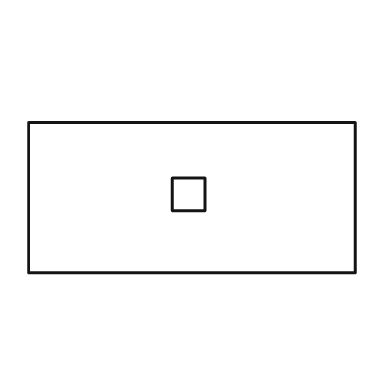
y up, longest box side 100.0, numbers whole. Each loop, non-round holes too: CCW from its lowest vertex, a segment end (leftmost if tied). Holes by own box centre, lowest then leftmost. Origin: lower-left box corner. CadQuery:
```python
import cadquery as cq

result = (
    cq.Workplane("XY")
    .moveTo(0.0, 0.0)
    .lineTo(100.0, 0.0)
    .lineTo(100.0, 46.0)
    .lineTo(0.0, 46.0)
    .close()
    .moveTo(44.0, 19.0)
    .lineTo(54.0, 19.0)
    .lineTo(54.0, 29.0)
    .lineTo(44.0, 29.0)
    .close()
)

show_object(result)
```